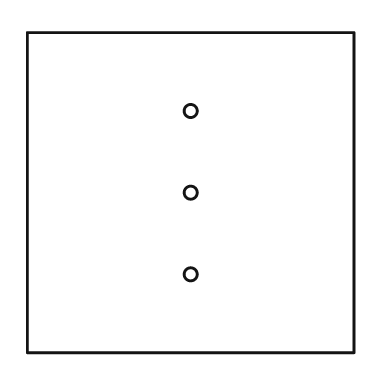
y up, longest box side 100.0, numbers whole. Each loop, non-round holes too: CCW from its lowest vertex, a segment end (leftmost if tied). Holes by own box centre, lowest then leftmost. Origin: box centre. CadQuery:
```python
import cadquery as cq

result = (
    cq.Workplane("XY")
    .moveTo(-50.0, -49.0)
    .lineTo(50.0, -49.0)
    .lineTo(50.0, 49.0)
    .lineTo(-50.0, 49.0)
    .close()
    .moveTo(0.0, -25.0)
    .circle(2.0)
    .moveTo(0.0, 0.0)
    .circle(2.0)
    .moveTo(0.0, 25.0)
    .circle(2.0)
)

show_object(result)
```